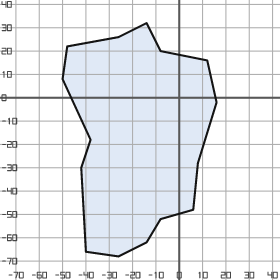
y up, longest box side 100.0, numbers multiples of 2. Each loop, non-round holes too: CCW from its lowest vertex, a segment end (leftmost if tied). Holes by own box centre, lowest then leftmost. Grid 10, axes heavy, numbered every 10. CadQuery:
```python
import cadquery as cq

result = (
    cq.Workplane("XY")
    .moveTo(-26.0, -68.0)
    .lineTo(-14.0, -62.0)
    .lineTo(-8.0, -52.0)
    .lineTo(6.0, -48.0)
    .lineTo(8.0, -28.0)
    .lineTo(16.0, -2.0)
    .lineTo(12.0, 16.0)
    .lineTo(-8.0, 20.0)
    .lineTo(-14.0, 32.0)
    .lineTo(-26.0, 26.0)
    .lineTo(-48.0, 22.0)
    .lineTo(-50.0, 8.0)
    .lineTo(-38.0, -18.0)
    .lineTo(-42.0, -30.0)
    .lineTo(-40.0, -66.0)
    .close()
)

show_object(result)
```